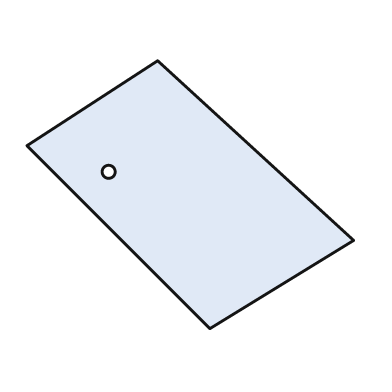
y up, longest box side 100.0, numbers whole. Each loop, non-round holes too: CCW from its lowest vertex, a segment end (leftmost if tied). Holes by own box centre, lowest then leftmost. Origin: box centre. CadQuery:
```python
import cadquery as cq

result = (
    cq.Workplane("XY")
    .moveTo(6.0, -41.0)
    .lineTo(50.0, -14.0)
    .lineTo(-10.0, 41.0)
    .lineTo(-50.0, 15.0)
    .close()
    .moveTo(-25.0, 7.0)
    .circle(2.0)
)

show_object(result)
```